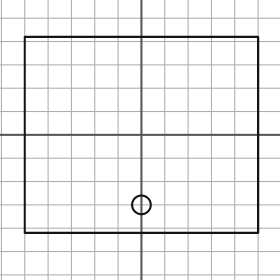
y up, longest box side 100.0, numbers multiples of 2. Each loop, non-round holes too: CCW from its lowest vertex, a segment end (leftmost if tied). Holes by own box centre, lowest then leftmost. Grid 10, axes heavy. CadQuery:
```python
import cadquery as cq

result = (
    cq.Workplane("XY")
    .moveTo(-50.0, -42.0)
    .lineTo(50.0, -42.0)
    .lineTo(50.0, 42.0)
    .lineTo(-50.0, 42.0)
    .close()
    .moveTo(0.0, -30.0)
    .circle(4.0)
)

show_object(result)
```